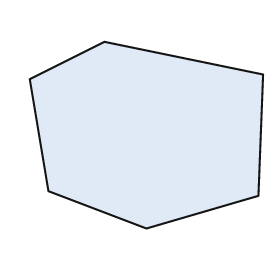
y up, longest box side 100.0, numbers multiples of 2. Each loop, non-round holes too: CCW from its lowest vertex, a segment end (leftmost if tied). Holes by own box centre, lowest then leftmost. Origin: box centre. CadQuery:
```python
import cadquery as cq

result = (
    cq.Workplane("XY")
    .moveTo(0.0, -40.0)
    .lineTo(48.0, -26.0)
    .lineTo(50.0, 26.0)
    .lineTo(-18.0, 40.0)
    .lineTo(-50.0, 24.0)
    .lineTo(-42.0, -24.0)
    .close()
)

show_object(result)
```